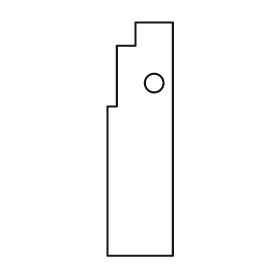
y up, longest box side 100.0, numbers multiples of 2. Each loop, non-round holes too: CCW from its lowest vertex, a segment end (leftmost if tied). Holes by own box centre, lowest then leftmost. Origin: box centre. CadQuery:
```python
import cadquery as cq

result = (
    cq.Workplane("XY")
    .moveTo(-14.0, -50.0)
    .lineTo(14.0, -50.0)
    .lineTo(14.0, 50.0)
    .lineTo(-2.0, 50.0)
    .lineTo(-2.0, 40.0)
    .lineTo(-10.0, 40.0)
    .lineTo(-10.0, 14.0)
    .lineTo(-14.0, 14.0)
    .close()
    .moveTo(6.0, 24.0)
    .circle(4.0)
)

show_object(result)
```